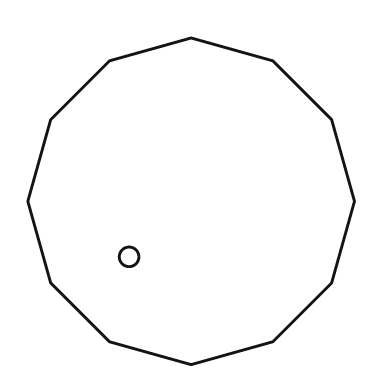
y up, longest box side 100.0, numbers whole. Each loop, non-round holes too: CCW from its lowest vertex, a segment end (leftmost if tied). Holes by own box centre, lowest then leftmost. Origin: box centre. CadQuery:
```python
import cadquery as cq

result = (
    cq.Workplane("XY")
    .moveTo(0.0, -50.0)
    .lineTo(25.0, -43.0)
    .lineTo(43.0, -25.0)
    .lineTo(50.0, 0.0)
    .lineTo(43.0, 25.0)
    .lineTo(25.0, 43.0)
    .lineTo(0.0, 50.0)
    .lineTo(-25.0, 43.0)
    .lineTo(-43.0, 25.0)
    .lineTo(-50.0, 0.0)
    .lineTo(-43.0, -25.0)
    .lineTo(-25.0, -43.0)
    .close()
    .moveTo(-19.0, -17.0)
    .circle(3.0)
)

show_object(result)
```